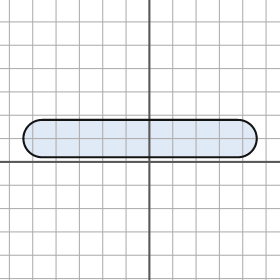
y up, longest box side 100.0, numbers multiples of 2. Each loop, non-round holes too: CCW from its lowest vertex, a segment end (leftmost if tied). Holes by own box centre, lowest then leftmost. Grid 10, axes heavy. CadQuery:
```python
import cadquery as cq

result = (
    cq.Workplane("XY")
    .moveTo(-46.0, 2.0)
    .lineTo(38.0, 2.0)
    .threePointArc((46.0, 10.0), (38.0, 18.0))
    .lineTo(-46.0, 18.0)
    .threePointArc((-54.0, 10.0), (-46.0, 2.0))
    .close()
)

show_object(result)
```